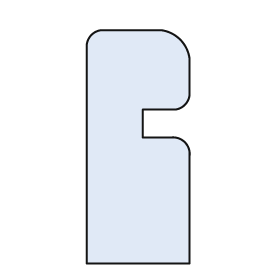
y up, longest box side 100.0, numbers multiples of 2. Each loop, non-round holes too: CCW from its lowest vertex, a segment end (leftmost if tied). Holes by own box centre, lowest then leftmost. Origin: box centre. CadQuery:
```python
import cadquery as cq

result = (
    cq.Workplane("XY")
    .moveTo(-22.0, -50.0)
    .lineTo(22.0, -50.0)
    .lineTo(22.0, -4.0)
    .threePointArc((20.0, 2.0), (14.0, 4.0))
    .lineTo(2.0, 4.0)
    .lineTo(2.0, 16.0)
    .lineTo(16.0, 16.0)
    .threePointArc((20.0, 18.0), (22.0, 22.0))
    .lineTo(22.0, 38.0)
    .threePointArc((18.0, 46.0), (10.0, 50.0))
    .lineTo(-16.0, 50.0)
    .threePointArc((-20.0, 48.0), (-22.0, 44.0))
    .close()
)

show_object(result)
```